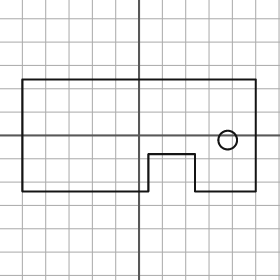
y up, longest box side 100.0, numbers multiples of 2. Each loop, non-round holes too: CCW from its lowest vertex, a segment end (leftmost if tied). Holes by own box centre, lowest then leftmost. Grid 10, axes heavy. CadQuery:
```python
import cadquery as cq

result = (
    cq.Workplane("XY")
    .moveTo(-50.0, -24.0)
    .lineTo(4.0, -24.0)
    .lineTo(4.0, -8.0)
    .lineTo(24.0, -8.0)
    .lineTo(24.0, -24.0)
    .lineTo(50.0, -24.0)
    .lineTo(50.0, 24.0)
    .lineTo(-50.0, 24.0)
    .close()
    .moveTo(38.0, -2.0)
    .circle(4.0)
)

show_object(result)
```